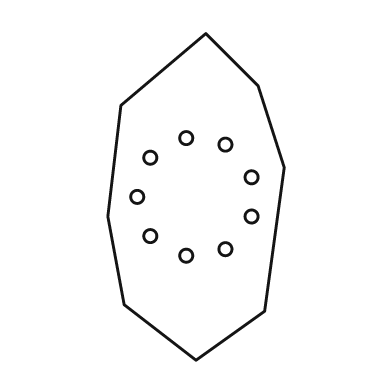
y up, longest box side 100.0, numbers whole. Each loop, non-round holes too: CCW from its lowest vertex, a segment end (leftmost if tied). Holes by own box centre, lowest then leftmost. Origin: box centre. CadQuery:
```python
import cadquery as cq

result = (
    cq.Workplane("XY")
    .moveTo(0.0, -50.0)
    .lineTo(21.0, -35.0)
    .lineTo(27.0, 9.0)
    .lineTo(19.0, 34.0)
    .lineTo(3.0, 50.0)
    .lineTo(-23.0, 28.0)
    .lineTo(-27.0, -6.0)
    .lineTo(-22.0, -33.0)
    .close()
    .moveTo(-3.0, -18.0)
    .circle(2.0)
    .moveTo(9.0, -16.0)
    .circle(2.0)
    .moveTo(-14.0, -12.0)
    .circle(2.0)
    .moveTo(17.0, -6.0)
    .circle(2.0)
    .moveTo(-18.0, 0.0)
    .circle(2.0)
    .moveTo(17.0, 6.0)
    .circle(2.0)
    .moveTo(-14.0, 12.0)
    .circle(2.0)
    .moveTo(9.0, 16.0)
    .circle(2.0)
    .moveTo(-3.0, 18.0)
    .circle(2.0)
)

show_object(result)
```